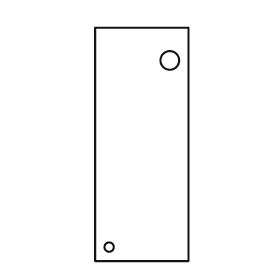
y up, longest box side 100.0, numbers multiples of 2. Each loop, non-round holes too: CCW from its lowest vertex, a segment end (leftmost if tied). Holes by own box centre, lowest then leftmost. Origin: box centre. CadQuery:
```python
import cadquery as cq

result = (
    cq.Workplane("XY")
    .moveTo(-20.0, -50.0)
    .lineTo(20.0, -50.0)
    .lineTo(20.0, 50.0)
    .lineTo(-20.0, 50.0)
    .close()
    .moveTo(-14.0, -44.0)
    .circle(2.0)
    .moveTo(12.0, 36.0)
    .circle(4.0)
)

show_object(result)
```